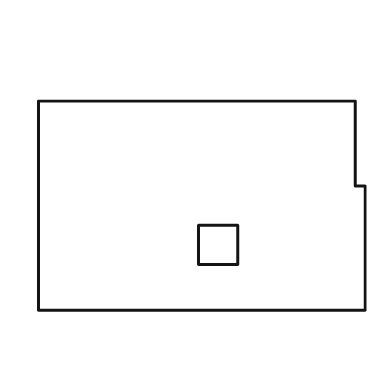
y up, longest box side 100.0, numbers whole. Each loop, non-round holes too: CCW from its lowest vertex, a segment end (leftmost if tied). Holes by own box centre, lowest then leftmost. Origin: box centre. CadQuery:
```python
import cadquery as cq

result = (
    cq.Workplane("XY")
    .moveTo(-50.0, -32.0)
    .lineTo(50.0, -32.0)
    .lineTo(50.0, 6.0)
    .lineTo(47.0, 6.0)
    .lineTo(47.0, 32.0)
    .lineTo(-50.0, 32.0)
    .close()
    .moveTo(-1.0, -18.0)
    .lineTo(11.0, -18.0)
    .lineTo(11.0, -6.0)
    .lineTo(-1.0, -6.0)
    .close()
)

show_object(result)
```